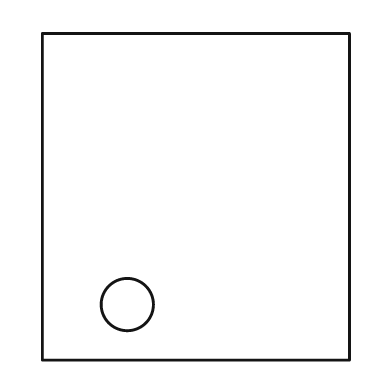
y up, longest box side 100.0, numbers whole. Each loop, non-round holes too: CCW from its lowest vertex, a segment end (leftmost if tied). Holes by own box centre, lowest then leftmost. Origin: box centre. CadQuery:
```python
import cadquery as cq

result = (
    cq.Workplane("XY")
    .moveTo(-47.0, -50.0)
    .lineTo(47.0, -50.0)
    .lineTo(47.0, 50.0)
    .lineTo(-47.0, 50.0)
    .close()
    .moveTo(-21.0, -33.0)
    .circle(8.0)
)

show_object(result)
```